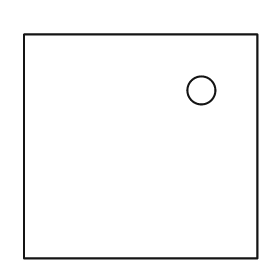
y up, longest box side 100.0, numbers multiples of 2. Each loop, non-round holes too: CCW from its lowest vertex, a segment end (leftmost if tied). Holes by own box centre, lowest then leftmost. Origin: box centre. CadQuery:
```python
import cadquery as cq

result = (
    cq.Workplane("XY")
    .moveTo(-50.0, -48.0)
    .lineTo(50.0, -48.0)
    .lineTo(50.0, 48.0)
    .lineTo(-50.0, 48.0)
    .close()
    .moveTo(26.0, 24.0)
    .circle(6.0)
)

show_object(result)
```